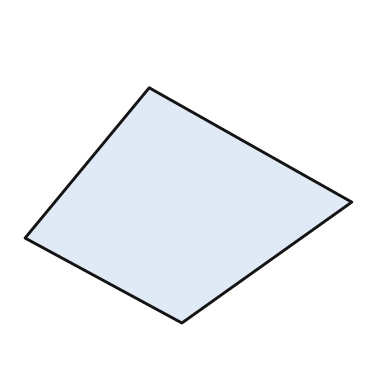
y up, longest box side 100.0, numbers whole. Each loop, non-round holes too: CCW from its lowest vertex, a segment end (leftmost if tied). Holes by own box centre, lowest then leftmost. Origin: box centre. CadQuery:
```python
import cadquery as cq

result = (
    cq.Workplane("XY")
    .moveTo(-2.0, -36.0)
    .lineTo(50.0, 1.0)
    .lineTo(-12.0, 36.0)
    .lineTo(-50.0, -10.0)
    .close()
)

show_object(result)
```